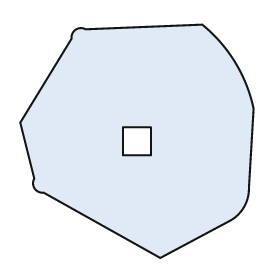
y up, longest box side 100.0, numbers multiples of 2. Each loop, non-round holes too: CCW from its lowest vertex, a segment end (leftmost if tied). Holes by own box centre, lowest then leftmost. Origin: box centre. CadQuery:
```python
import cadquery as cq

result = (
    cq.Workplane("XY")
    .moveTo(10.0, -50.0)
    .lineTo(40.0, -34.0)
    .threePointArc((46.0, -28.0), (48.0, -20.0))
    .lineTo(50.0, 14.0)
    .threePointArc((42.0, 34.0), (28.0, 50.0))
    .lineTo(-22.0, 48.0)
    .threePointArc((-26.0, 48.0), (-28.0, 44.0))
    .lineTo(-50.0, 8.0)
    .lineTo(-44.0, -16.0)
    .threePointArc((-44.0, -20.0), (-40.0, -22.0))
    .close()
    .moveTo(-6.0, -6.0)
    .lineTo(6.0, -6.0)
    .lineTo(6.0, 6.0)
    .lineTo(-6.0, 6.0)
    .close()
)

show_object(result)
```